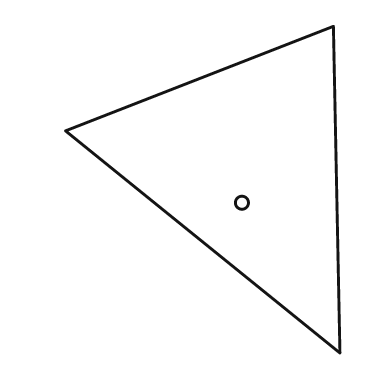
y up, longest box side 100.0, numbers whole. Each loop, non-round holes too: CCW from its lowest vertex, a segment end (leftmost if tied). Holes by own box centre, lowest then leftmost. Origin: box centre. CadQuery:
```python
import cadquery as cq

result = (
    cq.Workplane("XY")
    .moveTo(42.0, -50.0)
    .lineTo(40.0, 50.0)
    .lineTo(-42.0, 18.0)
    .close()
    .moveTo(12.0, -4.0)
    .circle(2.0)
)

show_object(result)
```